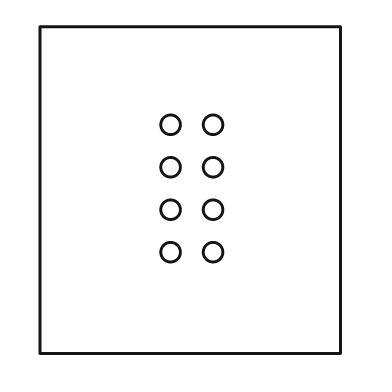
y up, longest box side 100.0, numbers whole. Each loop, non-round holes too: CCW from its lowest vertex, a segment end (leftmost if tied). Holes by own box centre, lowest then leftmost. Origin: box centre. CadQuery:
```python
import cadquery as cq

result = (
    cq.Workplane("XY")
    .moveTo(-46.0, -50.0)
    .lineTo(46.0, -50.0)
    .lineTo(46.0, 50.0)
    .lineTo(-46.0, 50.0)
    .close()
    .moveTo(-6.0, -19.0)
    .circle(3.0)
    .moveTo(7.0, -19.0)
    .circle(3.0)
    .moveTo(-6.0, -6.0)
    .circle(3.0)
    .moveTo(7.0, -6.0)
    .circle(3.0)
    .moveTo(-6.0, 7.0)
    .circle(3.0)
    .moveTo(7.0, 7.0)
    .circle(3.0)
    .moveTo(-6.0, 20.0)
    .circle(3.0)
    .moveTo(7.0, 20.0)
    .circle(3.0)
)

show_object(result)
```